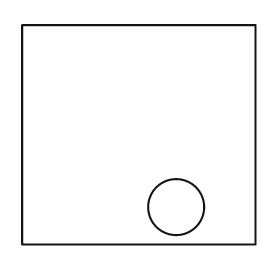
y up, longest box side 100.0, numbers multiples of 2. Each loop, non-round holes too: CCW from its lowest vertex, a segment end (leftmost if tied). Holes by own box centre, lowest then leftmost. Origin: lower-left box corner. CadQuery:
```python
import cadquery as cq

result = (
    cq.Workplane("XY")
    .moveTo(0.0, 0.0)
    .lineTo(100.0, 0.0)
    .lineTo(100.0, 94.0)
    .lineTo(0.0, 94.0)
    .close()
    .moveTo(66.0, 16.0)
    .circle(12.0)
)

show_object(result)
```